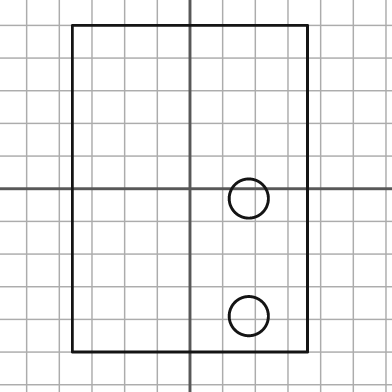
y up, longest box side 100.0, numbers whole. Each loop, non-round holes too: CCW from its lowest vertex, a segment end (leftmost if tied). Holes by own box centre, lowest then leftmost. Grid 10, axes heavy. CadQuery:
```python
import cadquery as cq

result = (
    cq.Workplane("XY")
    .moveTo(-36.0, -50.0)
    .lineTo(36.0, -50.0)
    .lineTo(36.0, 50.0)
    .lineTo(-36.0, 50.0)
    .close()
    .moveTo(18.0, -39.0)
    .circle(6.0)
    .moveTo(18.0, -3.0)
    .circle(6.0)
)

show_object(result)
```